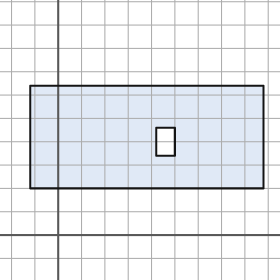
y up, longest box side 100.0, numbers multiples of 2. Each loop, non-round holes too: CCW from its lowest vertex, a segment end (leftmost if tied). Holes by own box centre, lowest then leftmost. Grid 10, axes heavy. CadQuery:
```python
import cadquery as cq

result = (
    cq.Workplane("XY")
    .moveTo(-12.0, 20.0)
    .lineTo(88.0, 20.0)
    .lineTo(88.0, 64.0)
    .lineTo(-12.0, 64.0)
    .close()
    .moveTo(42.0, 34.0)
    .lineTo(50.0, 34.0)
    .lineTo(50.0, 46.0)
    .lineTo(42.0, 46.0)
    .close()
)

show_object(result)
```